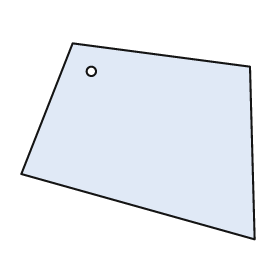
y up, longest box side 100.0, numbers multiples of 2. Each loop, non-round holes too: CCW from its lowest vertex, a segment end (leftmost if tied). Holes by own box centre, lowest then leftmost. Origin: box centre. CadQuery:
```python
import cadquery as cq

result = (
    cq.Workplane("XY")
    .moveTo(50.0, -42.0)
    .lineTo(48.0, 32.0)
    .lineTo(-28.0, 42.0)
    .lineTo(-50.0, -14.0)
    .close()
    .moveTo(-20.0, 30.0)
    .circle(2.0)
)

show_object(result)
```